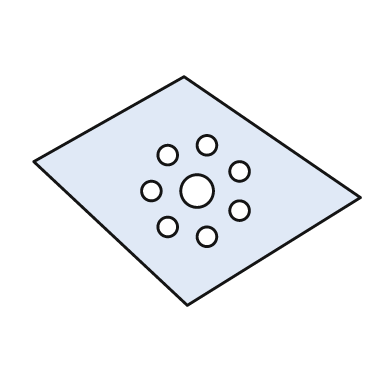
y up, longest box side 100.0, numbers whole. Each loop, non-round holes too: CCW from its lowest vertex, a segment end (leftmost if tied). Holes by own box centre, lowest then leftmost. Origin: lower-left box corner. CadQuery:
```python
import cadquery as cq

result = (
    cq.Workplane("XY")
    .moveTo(47.0, 0.0)
    .lineTo(100.0, 33.0)
    .lineTo(46.0, 70.0)
    .lineTo(0.0, 44.0)
    .close()
    .moveTo(53.0, 21.0)
    .circle(3.0)
    .moveTo(41.0, 24.0)
    .circle(3.0)
    .moveTo(63.0, 29.0)
    .circle(3.0)
    .moveTo(36.0, 35.0)
    .circle(3.0)
    .moveTo(50.0, 35.0)
    .circle(5.0)
    .moveTo(63.0, 41.0)
    .circle(3.0)
    .moveTo(41.0, 46.0)
    .circle(3.0)
    .moveTo(53.0, 49.0)
    .circle(3.0)
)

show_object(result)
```